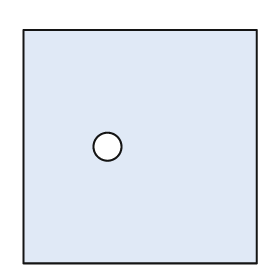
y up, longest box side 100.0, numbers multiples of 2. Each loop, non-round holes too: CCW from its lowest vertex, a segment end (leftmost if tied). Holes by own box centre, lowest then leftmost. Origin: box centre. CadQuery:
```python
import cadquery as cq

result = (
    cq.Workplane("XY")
    .moveTo(-50.0, -50.0)
    .lineTo(50.0, -50.0)
    .lineTo(50.0, 50.0)
    .lineTo(-50.0, 50.0)
    .close()
    .moveTo(-14.0, 0.0)
    .circle(6.0)
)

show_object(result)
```